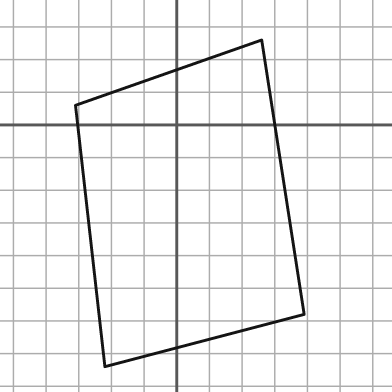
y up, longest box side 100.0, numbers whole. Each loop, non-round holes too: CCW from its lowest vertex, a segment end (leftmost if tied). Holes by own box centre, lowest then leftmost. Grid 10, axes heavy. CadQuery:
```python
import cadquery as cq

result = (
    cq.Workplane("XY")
    .moveTo(-22.0, -74.0)
    .lineTo(39.0, -58.0)
    .lineTo(26.0, 26.0)
    .lineTo(-31.0, 6.0)
    .close()
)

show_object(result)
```